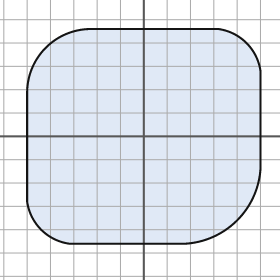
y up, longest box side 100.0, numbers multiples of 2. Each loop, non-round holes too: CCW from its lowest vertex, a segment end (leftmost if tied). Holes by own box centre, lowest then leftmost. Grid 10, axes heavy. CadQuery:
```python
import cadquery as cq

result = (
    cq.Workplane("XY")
    .moveTo(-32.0, -46.0)
    .lineTo(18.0, -46.0)
    .threePointArc((40.0, -36.0), (50.0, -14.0))
    .lineTo(50.0, 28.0)
    .threePointArc((44.0, 40.0), (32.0, 46.0))
    .lineTo(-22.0, 46.0)
    .threePointArc((-42.0, 38.0), (-50.0, 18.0))
    .lineTo(-50.0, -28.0)
    .threePointArc((-44.0, -40.0), (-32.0, -46.0))
    .close()
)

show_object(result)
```